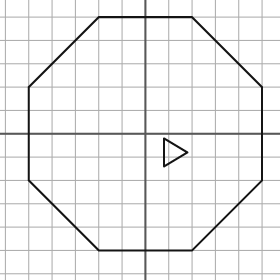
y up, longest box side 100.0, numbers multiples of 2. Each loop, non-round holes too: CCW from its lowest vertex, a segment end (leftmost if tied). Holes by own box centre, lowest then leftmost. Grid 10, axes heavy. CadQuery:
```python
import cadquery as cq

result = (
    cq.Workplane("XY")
    .moveTo(-20.0, -50.0)
    .lineTo(20.0, -50.0)
    .lineTo(50.0, -20.0)
    .lineTo(50.0, 20.0)
    .lineTo(20.0, 50.0)
    .lineTo(-20.0, 50.0)
    .lineTo(-50.0, 20.0)
    .lineTo(-50.0, -20.0)
    .close()
    .moveTo(8.0, -14.0)
    .lineTo(18.0, -8.0)
    .lineTo(8.0, -2.0)
    .close()
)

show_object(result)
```